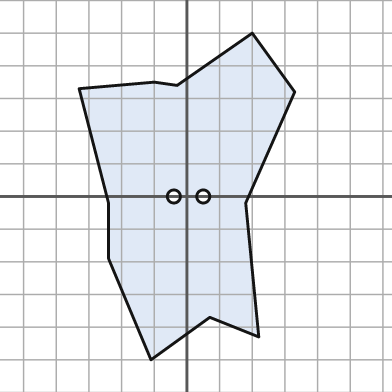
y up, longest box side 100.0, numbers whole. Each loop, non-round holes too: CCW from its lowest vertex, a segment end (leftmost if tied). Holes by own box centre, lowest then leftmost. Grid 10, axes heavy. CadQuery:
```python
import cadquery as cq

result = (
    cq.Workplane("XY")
    .moveTo(-11.0, -50.0)
    .lineTo(7.0, -37.0)
    .lineTo(22.0, -43.0)
    .lineTo(18.0, -2.0)
    .lineTo(33.0, 32.0)
    .lineTo(20.0, 50.0)
    .lineTo(-3.0, 34.0)
    .lineTo(-10.0, 35.0)
    .lineTo(-33.0, 33.0)
    .lineTo(-24.0, -2.0)
    .lineTo(-24.0, -19.0)
    .close()
    .moveTo(-4.0, 0.0)
    .circle(2.0)
    .moveTo(5.0, 0.0)
    .circle(2.0)
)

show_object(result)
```